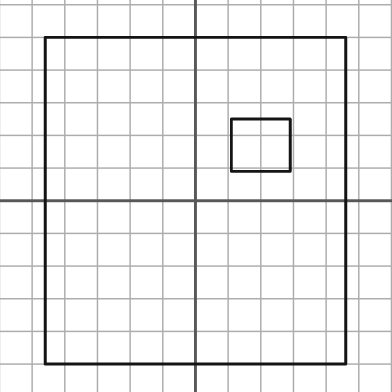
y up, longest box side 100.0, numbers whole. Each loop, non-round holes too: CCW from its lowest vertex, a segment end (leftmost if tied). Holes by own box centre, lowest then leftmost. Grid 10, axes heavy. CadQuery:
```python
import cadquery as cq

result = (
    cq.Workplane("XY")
    .moveTo(-46.0, -50.0)
    .lineTo(46.0, -50.0)
    .lineTo(46.0, 50.0)
    .lineTo(-46.0, 50.0)
    .close()
    .moveTo(11.0, 9.0)
    .lineTo(29.0, 9.0)
    .lineTo(29.0, 25.0)
    .lineTo(11.0, 25.0)
    .close()
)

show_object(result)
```